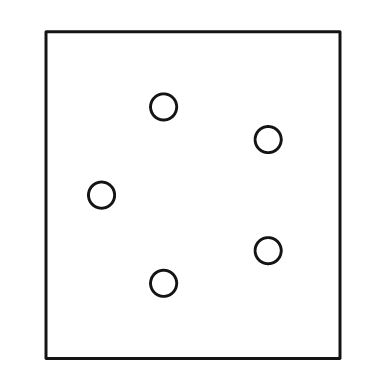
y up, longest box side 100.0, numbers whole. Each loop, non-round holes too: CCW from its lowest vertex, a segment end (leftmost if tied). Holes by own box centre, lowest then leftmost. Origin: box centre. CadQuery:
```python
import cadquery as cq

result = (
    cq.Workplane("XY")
    .moveTo(-45.0, -50.0)
    .lineTo(45.0, -50.0)
    .lineTo(45.0, 50.0)
    .lineTo(-45.0, 50.0)
    .close()
    .moveTo(-9.0, -27.0)
    .circle(4.0)
    .moveTo(23.0, -17.0)
    .circle(4.0)
    .moveTo(-28.0, 0.0)
    .circle(4.0)
    .moveTo(23.0, 17.0)
    .circle(4.0)
    .moveTo(-9.0, 27.0)
    .circle(4.0)
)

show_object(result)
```